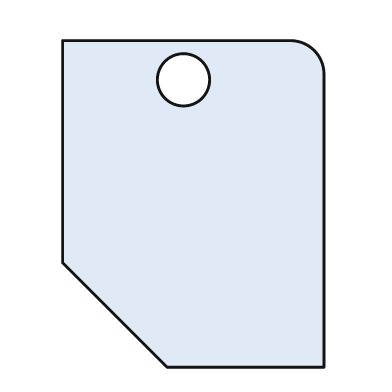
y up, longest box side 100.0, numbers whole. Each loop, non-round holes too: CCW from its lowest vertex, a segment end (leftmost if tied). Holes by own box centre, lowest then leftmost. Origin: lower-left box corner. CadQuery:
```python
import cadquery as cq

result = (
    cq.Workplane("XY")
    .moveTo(32.0, 0.0)
    .lineTo(80.0, 0.0)
    .lineTo(80.0, 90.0)
    .threePointArc((77.0, 97.0), (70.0, 100.0))
    .lineTo(0.0, 100.0)
    .lineTo(0.0, 32.0)
    .close()
    .moveTo(37.0, 88.0)
    .circle(8.0)
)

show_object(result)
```